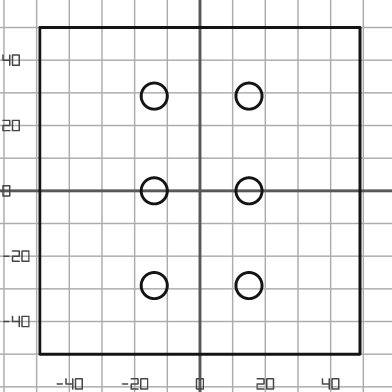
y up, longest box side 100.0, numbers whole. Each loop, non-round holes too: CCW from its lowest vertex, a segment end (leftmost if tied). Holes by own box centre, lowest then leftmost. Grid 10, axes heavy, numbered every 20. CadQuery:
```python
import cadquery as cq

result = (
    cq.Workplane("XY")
    .moveTo(-49.0, -50.0)
    .lineTo(49.0, -50.0)
    .lineTo(49.0, 50.0)
    .lineTo(-49.0, 50.0)
    .close()
    .moveTo(-14.0, -29.0)
    .circle(4.0)
    .moveTo(15.0, -29.0)
    .circle(4.0)
    .moveTo(-14.0, 0.0)
    .circle(4.0)
    .moveTo(15.0, 0.0)
    .circle(4.0)
    .moveTo(-14.0, 29.0)
    .circle(4.0)
    .moveTo(15.0, 29.0)
    .circle(4.0)
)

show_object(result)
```